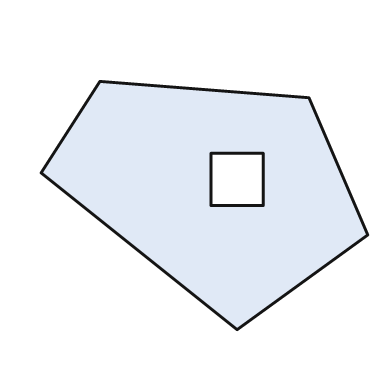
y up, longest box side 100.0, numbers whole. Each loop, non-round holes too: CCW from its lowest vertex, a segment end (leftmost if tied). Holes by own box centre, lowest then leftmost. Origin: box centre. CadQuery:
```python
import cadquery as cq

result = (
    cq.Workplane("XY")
    .moveTo(10.0, -38.0)
    .lineTo(50.0, -9.0)
    .lineTo(32.0, 33.0)
    .lineTo(-32.0, 38.0)
    .lineTo(-50.0, 10.0)
    .close()
    .moveTo(2.0, 0.0)
    .lineTo(18.0, 0.0)
    .lineTo(18.0, 16.0)
    .lineTo(2.0, 16.0)
    .close()
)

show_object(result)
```